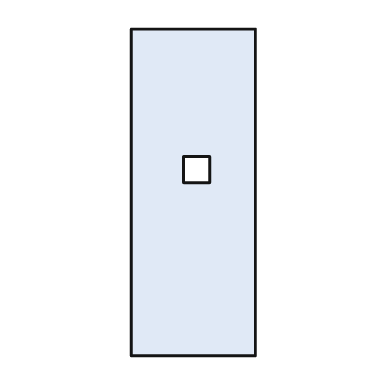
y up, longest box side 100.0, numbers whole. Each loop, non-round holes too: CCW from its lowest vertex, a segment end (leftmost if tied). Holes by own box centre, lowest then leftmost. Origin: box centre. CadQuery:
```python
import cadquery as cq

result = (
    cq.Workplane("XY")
    .moveTo(-19.0, -50.0)
    .lineTo(19.0, -50.0)
    .lineTo(19.0, 50.0)
    .lineTo(-19.0, 50.0)
    .close()
    .moveTo(-3.0, 3.0)
    .lineTo(5.0, 3.0)
    .lineTo(5.0, 11.0)
    .lineTo(-3.0, 11.0)
    .close()
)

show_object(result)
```